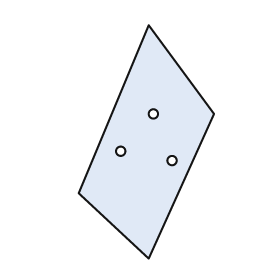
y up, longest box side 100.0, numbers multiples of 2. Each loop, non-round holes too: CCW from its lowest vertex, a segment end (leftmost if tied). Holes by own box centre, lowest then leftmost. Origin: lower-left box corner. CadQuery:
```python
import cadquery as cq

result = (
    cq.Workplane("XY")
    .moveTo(30.0, 0.0)
    .lineTo(58.0, 62.0)
    .lineTo(30.0, 100.0)
    .lineTo(0.0, 28.0)
    .close()
    .moveTo(40.0, 42.0)
    .circle(2.0)
    .moveTo(18.0, 46.0)
    .circle(2.0)
    .moveTo(32.0, 62.0)
    .circle(2.0)
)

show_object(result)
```